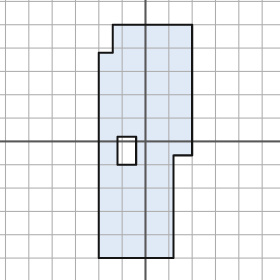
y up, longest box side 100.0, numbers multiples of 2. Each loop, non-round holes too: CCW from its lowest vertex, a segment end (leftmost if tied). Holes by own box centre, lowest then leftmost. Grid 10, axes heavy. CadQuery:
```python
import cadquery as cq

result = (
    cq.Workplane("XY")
    .moveTo(-20.0, -50.0)
    .lineTo(12.0, -50.0)
    .lineTo(12.0, -6.0)
    .lineTo(20.0, -6.0)
    .lineTo(20.0, 50.0)
    .lineTo(-14.0, 50.0)
    .lineTo(-14.0, 38.0)
    .lineTo(-20.0, 38.0)
    .close()
    .moveTo(-12.0, -10.0)
    .lineTo(-4.0, -10.0)
    .lineTo(-4.0, 2.0)
    .lineTo(-12.0, 2.0)
    .close()
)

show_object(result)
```